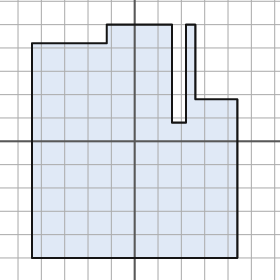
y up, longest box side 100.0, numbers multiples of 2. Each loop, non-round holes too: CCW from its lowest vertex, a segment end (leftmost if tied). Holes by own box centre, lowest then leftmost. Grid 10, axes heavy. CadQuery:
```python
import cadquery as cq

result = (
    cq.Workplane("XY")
    .moveTo(-44.0, -50.0)
    .lineTo(44.0, -50.0)
    .lineTo(44.0, 18.0)
    .lineTo(26.0, 18.0)
    .lineTo(26.0, 50.0)
    .lineTo(22.0, 50.0)
    .lineTo(22.0, 8.0)
    .lineTo(16.0, 8.0)
    .lineTo(16.0, 50.0)
    .lineTo(-12.0, 50.0)
    .lineTo(-12.0, 42.0)
    .lineTo(-44.0, 42.0)
    .close()
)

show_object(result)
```